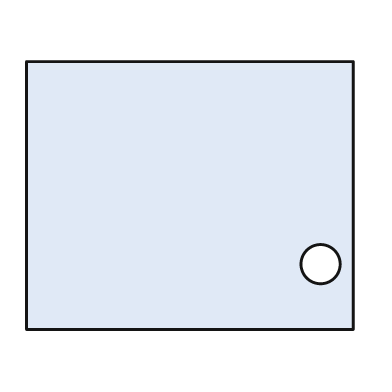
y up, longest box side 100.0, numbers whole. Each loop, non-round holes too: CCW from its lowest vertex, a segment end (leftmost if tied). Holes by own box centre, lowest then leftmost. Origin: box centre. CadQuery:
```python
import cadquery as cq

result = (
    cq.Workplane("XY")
    .moveTo(-50.0, -41.0)
    .lineTo(50.0, -41.0)
    .lineTo(50.0, 41.0)
    .lineTo(-50.0, 41.0)
    .close()
    .moveTo(40.0, -21.0)
    .circle(6.0)
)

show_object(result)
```